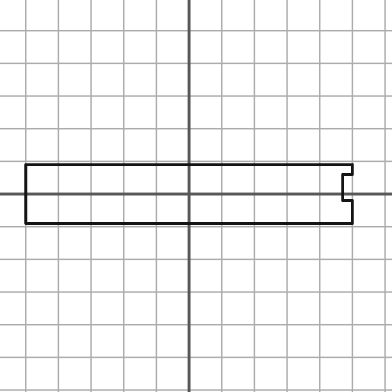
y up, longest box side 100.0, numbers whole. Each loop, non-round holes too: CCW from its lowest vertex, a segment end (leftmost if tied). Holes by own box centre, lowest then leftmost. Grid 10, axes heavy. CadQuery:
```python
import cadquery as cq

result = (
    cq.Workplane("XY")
    .moveTo(-50.0, -9.0)
    .lineTo(50.0, -9.0)
    .lineTo(50.0, -2.0)
    .lineTo(47.0, -2.0)
    .lineTo(47.0, 6.0)
    .lineTo(50.0, 6.0)
    .lineTo(50.0, 9.0)
    .lineTo(-50.0, 9.0)
    .close()
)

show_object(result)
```